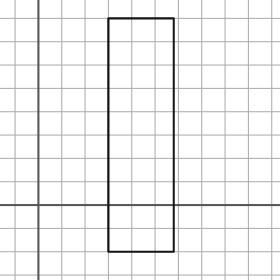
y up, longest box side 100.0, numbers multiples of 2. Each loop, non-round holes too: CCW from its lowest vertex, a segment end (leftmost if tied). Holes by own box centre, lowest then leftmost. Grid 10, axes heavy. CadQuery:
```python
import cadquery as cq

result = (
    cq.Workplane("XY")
    .moveTo(30.0, -20.0)
    .lineTo(58.0, -20.0)
    .lineTo(58.0, 80.0)
    .lineTo(30.0, 80.0)
    .close()
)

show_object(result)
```